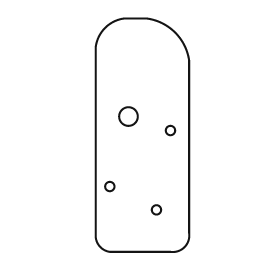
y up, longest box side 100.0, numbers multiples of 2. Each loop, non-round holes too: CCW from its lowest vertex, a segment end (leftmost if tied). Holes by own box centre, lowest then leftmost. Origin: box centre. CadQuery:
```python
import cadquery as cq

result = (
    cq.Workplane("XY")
    .moveTo(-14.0, -50.0)
    .lineTo(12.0, -50.0)
    .threePointArc((18.0, -48.0), (20.0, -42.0))
    .lineTo(20.0, 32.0)
    .threePointArc((14.0, 44.0), (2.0, 50.0))
    .lineTo(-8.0, 50.0)
    .threePointArc((-16.0, 46.0), (-20.0, 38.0))
    .lineTo(-20.0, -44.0)
    .threePointArc((-18.0, -48.0), (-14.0, -50.0))
    .close()
    .moveTo(6.0, -32.0)
    .circle(2.0)
    .moveTo(-14.0, -22.0)
    .circle(2.0)
    .moveTo(12.0, 2.0)
    .circle(2.0)
    .moveTo(-6.0, 8.0)
    .circle(4.0)
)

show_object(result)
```